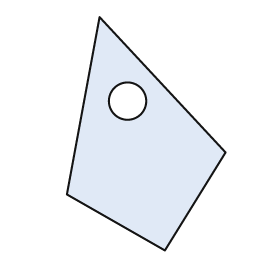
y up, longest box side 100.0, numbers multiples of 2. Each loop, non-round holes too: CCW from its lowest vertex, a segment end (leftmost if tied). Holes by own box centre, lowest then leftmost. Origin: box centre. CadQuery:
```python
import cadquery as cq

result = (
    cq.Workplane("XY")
    .moveTo(8.0, -50.0)
    .lineTo(34.0, -8.0)
    .lineTo(-20.0, 50.0)
    .lineTo(-34.0, -26.0)
    .close()
    .moveTo(-8.0, 14.0)
    .circle(8.0)
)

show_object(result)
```